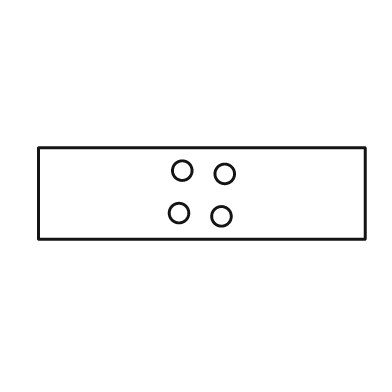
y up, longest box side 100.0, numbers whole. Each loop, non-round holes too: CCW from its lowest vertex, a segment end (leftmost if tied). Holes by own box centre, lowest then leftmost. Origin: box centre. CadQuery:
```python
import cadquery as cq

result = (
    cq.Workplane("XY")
    .moveTo(-50.0, -14.0)
    .lineTo(50.0, -14.0)
    .lineTo(50.0, 14.0)
    .lineTo(-50.0, 14.0)
    .close()
    .moveTo(6.0, -7.0)
    .circle(3.0)
    .moveTo(-7.0, -6.0)
    .circle(3.0)
    .moveTo(7.0, 6.0)
    .circle(3.0)
    .moveTo(-6.0, 7.0)
    .circle(3.0)
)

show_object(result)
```